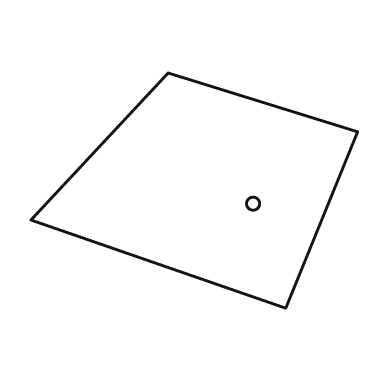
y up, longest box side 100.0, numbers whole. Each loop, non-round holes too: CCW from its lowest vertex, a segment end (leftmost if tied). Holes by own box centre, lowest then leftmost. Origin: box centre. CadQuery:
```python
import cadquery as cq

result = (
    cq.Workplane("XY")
    .moveTo(28.0, -36.0)
    .lineTo(50.0, 18.0)
    .lineTo(-8.0, 36.0)
    .lineTo(-50.0, -9.0)
    .close()
    .moveTo(18.0, -4.0)
    .circle(2.0)
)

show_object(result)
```